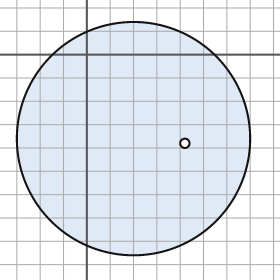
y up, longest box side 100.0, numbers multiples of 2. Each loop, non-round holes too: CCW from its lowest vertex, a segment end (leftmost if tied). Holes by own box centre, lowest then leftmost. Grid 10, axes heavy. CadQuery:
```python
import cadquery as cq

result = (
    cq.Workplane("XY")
    .moveTo(20.0, -36.0)
    .circle(50.0)
    .moveTo(42.0, -38.0)
    .circle(2.0)
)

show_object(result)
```